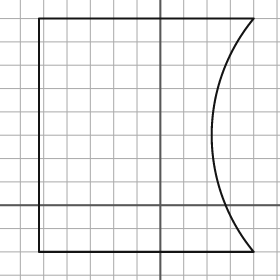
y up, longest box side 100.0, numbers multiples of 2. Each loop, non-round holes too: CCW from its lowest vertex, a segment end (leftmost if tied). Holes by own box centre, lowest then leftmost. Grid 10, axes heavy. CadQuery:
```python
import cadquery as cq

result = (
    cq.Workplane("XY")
    .moveTo(-52.0, -20.0)
    .lineTo(40.0, -20.0)
    .threePointArc((22.0, 30.0), (40.0, 80.0))
    .lineTo(-52.0, 80.0)
    .close()
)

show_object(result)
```